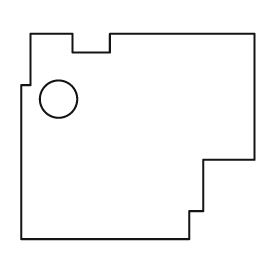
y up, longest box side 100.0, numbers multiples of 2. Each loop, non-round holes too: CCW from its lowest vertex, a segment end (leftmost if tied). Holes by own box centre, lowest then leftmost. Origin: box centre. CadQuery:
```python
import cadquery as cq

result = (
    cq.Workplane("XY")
    .moveTo(-50.0, -44.0)
    .lineTo(22.0, -44.0)
    .lineTo(22.0, -32.0)
    .lineTo(28.0, -32.0)
    .lineTo(28.0, -10.0)
    .lineTo(50.0, -10.0)
    .lineTo(50.0, 44.0)
    .lineTo(-12.0, 44.0)
    .lineTo(-12.0, 36.0)
    .lineTo(-28.0, 36.0)
    .lineTo(-28.0, 44.0)
    .lineTo(-46.0, 44.0)
    .lineTo(-46.0, 22.0)
    .lineTo(-50.0, 22.0)
    .close()
    .moveTo(-34.0, 16.0)
    .circle(8.0)
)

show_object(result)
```